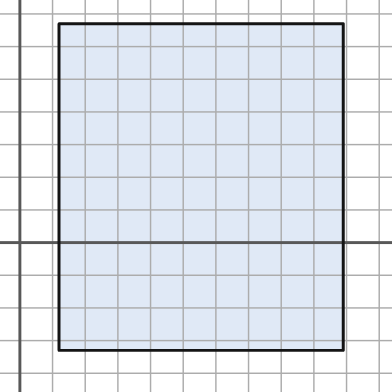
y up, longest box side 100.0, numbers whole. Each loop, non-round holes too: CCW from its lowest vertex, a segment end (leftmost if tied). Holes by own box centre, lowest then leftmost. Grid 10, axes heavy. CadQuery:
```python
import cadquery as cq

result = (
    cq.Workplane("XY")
    .moveTo(12.0, -33.0)
    .lineTo(99.0, -33.0)
    .lineTo(99.0, 67.0)
    .lineTo(12.0, 67.0)
    .close()
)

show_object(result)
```